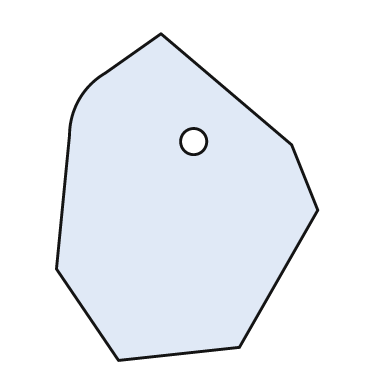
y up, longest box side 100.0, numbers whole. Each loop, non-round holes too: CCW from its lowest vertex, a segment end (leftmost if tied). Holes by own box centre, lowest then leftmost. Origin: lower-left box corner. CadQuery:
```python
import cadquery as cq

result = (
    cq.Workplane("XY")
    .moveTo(19.0, 0.0)
    .lineTo(56.0, 4.0)
    .lineTo(80.0, 46.0)
    .lineTo(72.0, 66.0)
    .lineTo(32.0, 100.0)
    .lineTo(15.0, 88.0)
    .threePointArc((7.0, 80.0), (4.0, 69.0))
    .lineTo(0.0, 28.0)
    .close()
    .moveTo(42.0, 67.0)
    .circle(4.0)
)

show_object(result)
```